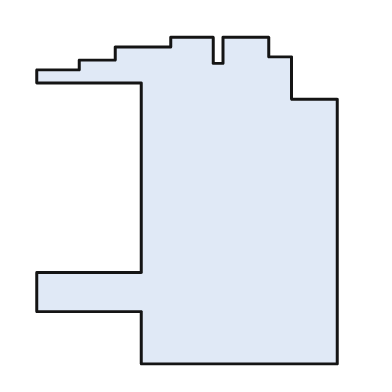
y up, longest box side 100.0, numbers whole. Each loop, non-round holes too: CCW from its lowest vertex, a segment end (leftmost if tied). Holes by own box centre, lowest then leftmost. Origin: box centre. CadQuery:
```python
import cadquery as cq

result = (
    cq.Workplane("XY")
    .moveTo(-14.0, -50.0)
    .lineTo(46.0, -50.0)
    .lineTo(46.0, 31.0)
    .lineTo(32.0, 31.0)
    .lineTo(32.0, 44.0)
    .lineTo(25.0, 44.0)
    .lineTo(25.0, 50.0)
    .lineTo(11.0, 50.0)
    .lineTo(11.0, 42.0)
    .lineTo(8.0, 42.0)
    .lineTo(8.0, 50.0)
    .lineTo(-5.0, 50.0)
    .lineTo(-5.0, 47.0)
    .lineTo(-22.0, 47.0)
    .lineTo(-22.0, 43.0)
    .lineTo(-33.0, 43.0)
    .lineTo(-33.0, 40.0)
    .lineTo(-46.0, 40.0)
    .lineTo(-46.0, 36.0)
    .lineTo(-14.0, 36.0)
    .lineTo(-14.0, -22.0)
    .lineTo(-46.0, -22.0)
    .lineTo(-46.0, -34.0)
    .lineTo(-14.0, -34.0)
    .close()
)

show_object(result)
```